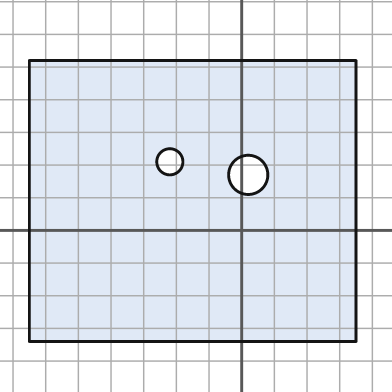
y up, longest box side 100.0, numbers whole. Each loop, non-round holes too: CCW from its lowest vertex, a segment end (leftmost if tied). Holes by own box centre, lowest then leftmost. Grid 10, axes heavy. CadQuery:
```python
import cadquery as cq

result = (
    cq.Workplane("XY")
    .moveTo(-65.0, -34.0)
    .lineTo(35.0, -34.0)
    .lineTo(35.0, 52.0)
    .lineTo(-65.0, 52.0)
    .close()
    .moveTo(2.0, 17.0)
    .circle(6.0)
    .moveTo(-22.0, 21.0)
    .circle(4.0)
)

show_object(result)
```